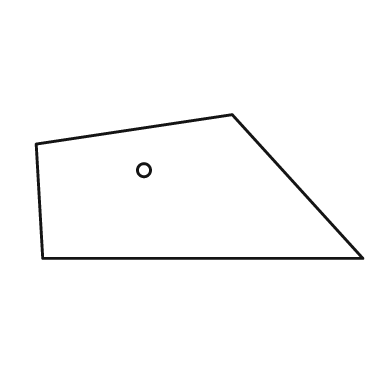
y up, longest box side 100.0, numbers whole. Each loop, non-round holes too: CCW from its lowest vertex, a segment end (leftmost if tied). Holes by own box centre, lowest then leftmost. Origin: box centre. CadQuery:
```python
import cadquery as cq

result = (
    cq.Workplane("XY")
    .moveTo(-48.0, -22.0)
    .lineTo(50.0, -22.0)
    .lineTo(10.0, 22.0)
    .lineTo(-50.0, 13.0)
    .close()
    .moveTo(-17.0, 5.0)
    .circle(2.0)
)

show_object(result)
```